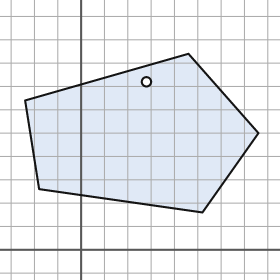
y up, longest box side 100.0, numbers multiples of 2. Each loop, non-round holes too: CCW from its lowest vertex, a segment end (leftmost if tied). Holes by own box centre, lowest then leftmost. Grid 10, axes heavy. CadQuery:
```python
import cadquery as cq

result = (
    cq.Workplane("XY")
    .moveTo(52.0, 16.0)
    .lineTo(76.0, 50.0)
    .lineTo(46.0, 84.0)
    .lineTo(-24.0, 64.0)
    .lineTo(-18.0, 26.0)
    .close()
    .moveTo(28.0, 72.0)
    .circle(2.0)
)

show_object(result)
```